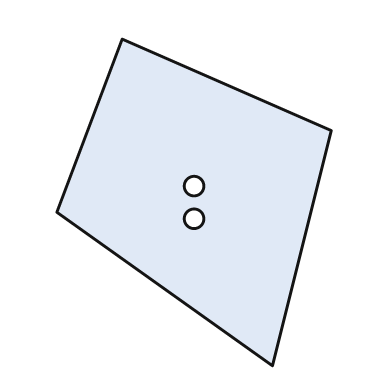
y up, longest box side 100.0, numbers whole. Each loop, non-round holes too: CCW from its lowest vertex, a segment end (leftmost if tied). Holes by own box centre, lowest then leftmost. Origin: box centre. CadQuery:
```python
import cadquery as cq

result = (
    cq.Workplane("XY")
    .moveTo(24.0, -50.0)
    .lineTo(42.0, 22.0)
    .lineTo(-22.0, 50.0)
    .lineTo(-42.0, -3.0)
    .close()
    .moveTo(0.0, -5.0)
    .circle(3.0)
    .moveTo(0.0, 5.0)
    .circle(3.0)
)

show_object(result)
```